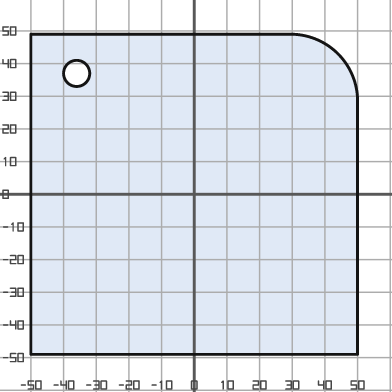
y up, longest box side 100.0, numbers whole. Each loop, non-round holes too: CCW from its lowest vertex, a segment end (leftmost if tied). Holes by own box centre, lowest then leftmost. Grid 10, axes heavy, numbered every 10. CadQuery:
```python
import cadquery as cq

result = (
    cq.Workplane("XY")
    .moveTo(-50.0, -49.0)
    .lineTo(50.0, -49.0)
    .lineTo(50.0, 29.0)
    .threePointArc((44.0, 43.0), (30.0, 49.0))
    .lineTo(-50.0, 49.0)
    .close()
    .moveTo(-36.0, 37.0)
    .circle(4.0)
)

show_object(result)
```